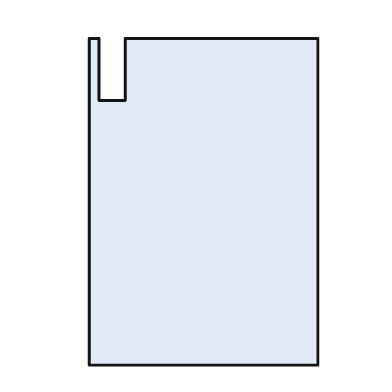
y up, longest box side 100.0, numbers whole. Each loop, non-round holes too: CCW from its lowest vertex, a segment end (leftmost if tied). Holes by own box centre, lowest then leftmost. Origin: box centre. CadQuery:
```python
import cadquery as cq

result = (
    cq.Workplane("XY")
    .moveTo(-35.0, -50.0)
    .lineTo(35.0, -50.0)
    .lineTo(35.0, 50.0)
    .lineTo(-24.0, 50.0)
    .lineTo(-24.0, 31.0)
    .lineTo(-32.0, 31.0)
    .lineTo(-32.0, 50.0)
    .lineTo(-35.0, 50.0)
    .close()
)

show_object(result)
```